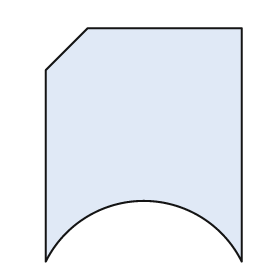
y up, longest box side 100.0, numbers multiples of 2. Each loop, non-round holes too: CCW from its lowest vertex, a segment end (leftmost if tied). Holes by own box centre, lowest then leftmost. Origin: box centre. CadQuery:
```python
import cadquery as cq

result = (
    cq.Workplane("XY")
    .moveTo(-42.0, -50.0)
    .threePointArc((0.0, -24.0), (42.0, -50.0))
    .lineTo(42.0, 50.0)
    .lineTo(-24.0, 50.0)
    .lineTo(-42.0, 32.0)
    .close()
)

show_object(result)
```